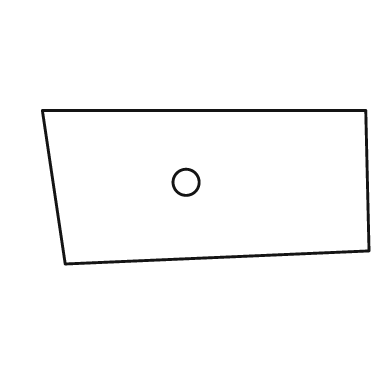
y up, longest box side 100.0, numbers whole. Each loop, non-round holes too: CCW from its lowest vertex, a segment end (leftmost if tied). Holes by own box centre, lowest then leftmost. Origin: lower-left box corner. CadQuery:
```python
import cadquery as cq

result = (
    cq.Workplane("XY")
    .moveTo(7.0, 0.0)
    .lineTo(100.0, 4.0)
    .lineTo(99.0, 47.0)
    .lineTo(0.0, 47.0)
    .close()
    .moveTo(44.0, 25.0)
    .circle(4.0)
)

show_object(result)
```